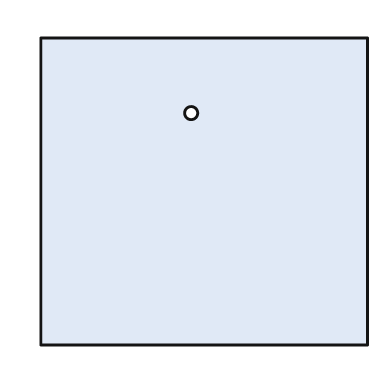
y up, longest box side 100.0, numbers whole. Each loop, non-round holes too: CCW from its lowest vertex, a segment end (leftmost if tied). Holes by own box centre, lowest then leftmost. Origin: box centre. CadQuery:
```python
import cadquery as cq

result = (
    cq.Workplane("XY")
    .moveTo(-50.0, -47.0)
    .lineTo(50.0, -47.0)
    .lineTo(50.0, 47.0)
    .lineTo(-50.0, 47.0)
    .close()
    .moveTo(-4.0, 24.0)
    .circle(2.0)
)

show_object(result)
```